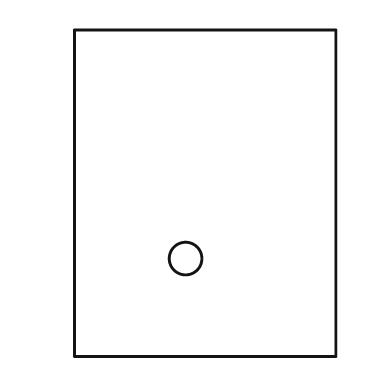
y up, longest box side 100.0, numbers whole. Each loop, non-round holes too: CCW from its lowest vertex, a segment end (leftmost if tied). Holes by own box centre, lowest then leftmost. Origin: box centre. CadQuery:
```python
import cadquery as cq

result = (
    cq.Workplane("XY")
    .moveTo(-40.0, -50.0)
    .lineTo(40.0, -50.0)
    .lineTo(40.0, 50.0)
    .lineTo(-40.0, 50.0)
    .close()
    .moveTo(-6.0, -20.0)
    .circle(5.0)
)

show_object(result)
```